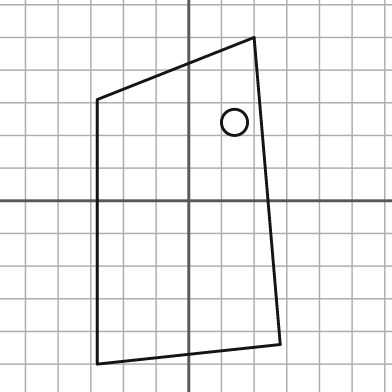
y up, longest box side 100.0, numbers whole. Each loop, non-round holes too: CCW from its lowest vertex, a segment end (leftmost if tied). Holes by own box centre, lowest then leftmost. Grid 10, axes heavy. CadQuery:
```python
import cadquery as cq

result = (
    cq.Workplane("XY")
    .moveTo(-28.0, -50.0)
    .lineTo(28.0, -44.0)
    .lineTo(20.0, 50.0)
    .lineTo(-28.0, 31.0)
    .close()
    .moveTo(14.0, 24.0)
    .circle(4.0)
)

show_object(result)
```